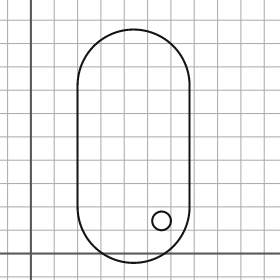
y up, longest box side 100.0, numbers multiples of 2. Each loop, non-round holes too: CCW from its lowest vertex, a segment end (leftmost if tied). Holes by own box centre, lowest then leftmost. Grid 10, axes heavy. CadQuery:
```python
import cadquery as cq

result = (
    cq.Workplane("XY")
    .moveTo(20.0, 20.0)
    .threePointArc((44.0, -4.0), (68.0, 20.0))
    .lineTo(68.0, 72.0)
    .threePointArc((44.0, 96.0), (20.0, 72.0))
    .close()
    .moveTo(56.0, 14.0)
    .circle(4.0)
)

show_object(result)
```